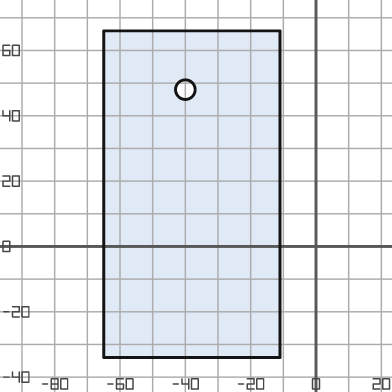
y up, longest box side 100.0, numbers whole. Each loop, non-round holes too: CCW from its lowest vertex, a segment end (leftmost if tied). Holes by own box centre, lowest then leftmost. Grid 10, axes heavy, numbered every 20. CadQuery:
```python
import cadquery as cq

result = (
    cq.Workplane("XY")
    .moveTo(-65.0, -34.0)
    .lineTo(-11.0, -34.0)
    .lineTo(-11.0, 66.0)
    .lineTo(-65.0, 66.0)
    .close()
    .moveTo(-40.0, 48.0)
    .circle(3.0)
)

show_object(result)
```